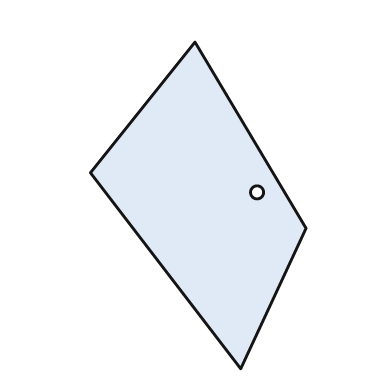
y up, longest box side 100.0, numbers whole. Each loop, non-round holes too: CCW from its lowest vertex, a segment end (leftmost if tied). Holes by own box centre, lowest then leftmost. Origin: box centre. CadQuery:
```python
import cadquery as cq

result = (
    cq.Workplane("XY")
    .moveTo(13.0, -50.0)
    .lineTo(33.0, -7.0)
    .lineTo(-1.0, 50.0)
    .lineTo(-33.0, 10.0)
    .close()
    .moveTo(18.0, 4.0)
    .circle(2.0)
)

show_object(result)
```